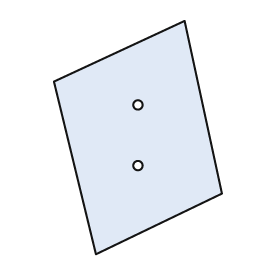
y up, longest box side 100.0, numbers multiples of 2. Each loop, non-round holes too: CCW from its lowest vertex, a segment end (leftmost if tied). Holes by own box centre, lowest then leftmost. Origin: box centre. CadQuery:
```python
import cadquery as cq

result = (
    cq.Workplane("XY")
    .moveTo(-18.0, -50.0)
    .lineTo(36.0, -24.0)
    .lineTo(20.0, 50.0)
    .lineTo(-36.0, 24.0)
    .close()
    .moveTo(0.0, -12.0)
    .circle(2.0)
    .moveTo(0.0, 14.0)
    .circle(2.0)
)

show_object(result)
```